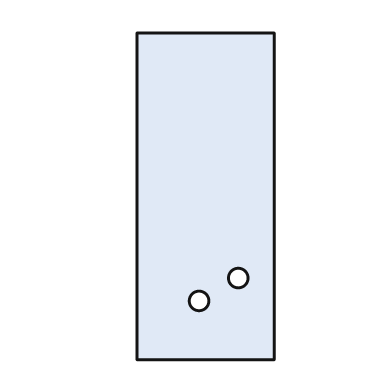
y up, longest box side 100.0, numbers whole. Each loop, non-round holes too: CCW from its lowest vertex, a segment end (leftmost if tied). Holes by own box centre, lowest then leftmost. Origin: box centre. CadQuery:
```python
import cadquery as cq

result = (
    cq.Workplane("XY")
    .moveTo(-21.0, -50.0)
    .lineTo(21.0, -50.0)
    .lineTo(21.0, 50.0)
    .lineTo(-21.0, 50.0)
    .close()
    .moveTo(-2.0, -32.0)
    .circle(3.0)
    .moveTo(10.0, -25.0)
    .circle(3.0)
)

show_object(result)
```